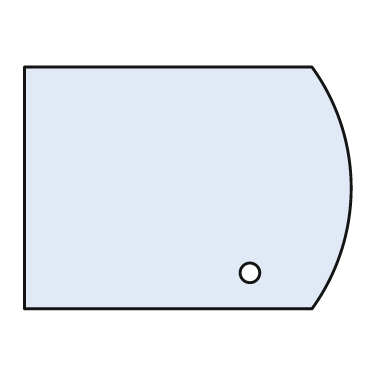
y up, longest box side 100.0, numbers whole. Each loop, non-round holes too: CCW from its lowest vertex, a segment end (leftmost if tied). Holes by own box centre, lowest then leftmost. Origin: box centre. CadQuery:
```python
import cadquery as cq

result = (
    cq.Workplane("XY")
    .moveTo(-50.0, -37.0)
    .lineTo(38.0, -37.0)
    .threePointArc((50.0, 0.0), (38.0, 37.0))
    .lineTo(-50.0, 37.0)
    .close()
    .moveTo(19.0, -26.0)
    .circle(3.0)
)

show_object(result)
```